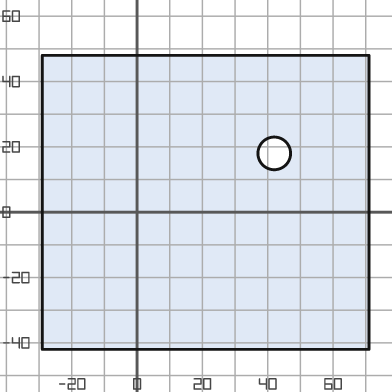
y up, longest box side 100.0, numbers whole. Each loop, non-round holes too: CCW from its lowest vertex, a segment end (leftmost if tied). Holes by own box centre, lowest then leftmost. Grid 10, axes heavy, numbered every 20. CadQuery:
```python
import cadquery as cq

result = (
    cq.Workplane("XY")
    .moveTo(-29.0, -42.0)
    .lineTo(71.0, -42.0)
    .lineTo(71.0, 48.0)
    .lineTo(-29.0, 48.0)
    .close()
    .moveTo(42.0, 18.0)
    .circle(5.0)
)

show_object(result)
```